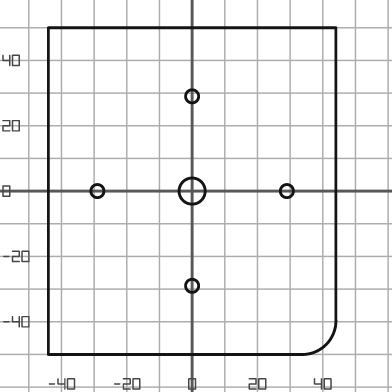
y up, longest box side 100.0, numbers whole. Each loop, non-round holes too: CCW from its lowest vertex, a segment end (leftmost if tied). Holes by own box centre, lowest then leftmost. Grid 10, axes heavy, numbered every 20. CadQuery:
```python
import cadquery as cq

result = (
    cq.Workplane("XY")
    .moveTo(-44.0, -50.0)
    .lineTo(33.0, -50.0)
    .threePointArc((41.0, -47.0), (44.0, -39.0))
    .lineTo(44.0, 50.0)
    .lineTo(-44.0, 50.0)
    .close()
    .moveTo(0.0, -29.0)
    .circle(2.0)
    .moveTo(-29.0, 0.0)
    .circle(2.0)
    .moveTo(0.0, 0.0)
    .circle(4.0)
    .moveTo(29.0, 0.0)
    .circle(2.0)
    .moveTo(0.0, 29.0)
    .circle(2.0)
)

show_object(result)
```